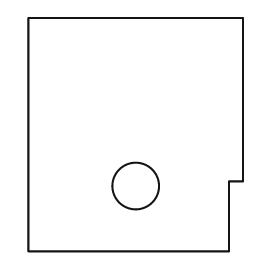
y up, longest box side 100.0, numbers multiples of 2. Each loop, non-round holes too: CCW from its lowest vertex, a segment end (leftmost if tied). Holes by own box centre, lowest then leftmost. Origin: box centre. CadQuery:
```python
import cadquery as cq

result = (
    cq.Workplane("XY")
    .moveTo(-46.0, -50.0)
    .lineTo(40.0, -50.0)
    .lineTo(40.0, -20.0)
    .lineTo(46.0, -20.0)
    .lineTo(46.0, 50.0)
    .lineTo(-46.0, 50.0)
    .close()
    .moveTo(0.0, -22.0)
    .circle(10.0)
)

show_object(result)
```